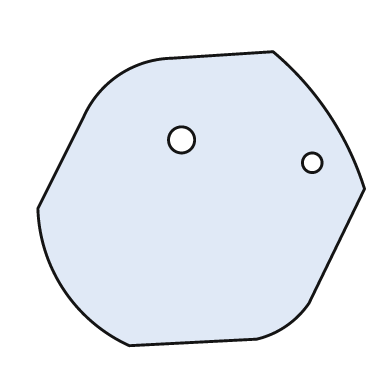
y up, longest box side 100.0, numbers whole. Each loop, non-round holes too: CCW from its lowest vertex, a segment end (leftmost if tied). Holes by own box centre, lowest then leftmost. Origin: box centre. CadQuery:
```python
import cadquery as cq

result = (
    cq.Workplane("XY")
    .moveTo(-22.0, -45.0)
    .lineTo(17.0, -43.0)
    .threePointArc((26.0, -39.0), (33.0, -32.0))
    .lineTo(50.0, 3.0)
    .threePointArc((39.0, 26.0), (22.0, 45.0))
    .lineTo(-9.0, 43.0)
    .threePointArc((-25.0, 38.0), (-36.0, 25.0))
    .lineTo(-50.0, -3.0)
    .threePointArc((-42.0, -28.0), (-22.0, -45.0))
    .close()
    .moveTo(34.0, 11.0)
    .circle(3.0)
    .moveTo(-6.0, 18.0)
    .circle(4.0)
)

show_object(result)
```